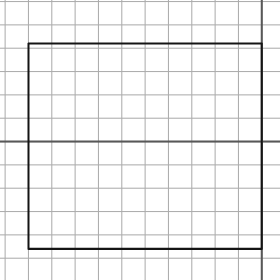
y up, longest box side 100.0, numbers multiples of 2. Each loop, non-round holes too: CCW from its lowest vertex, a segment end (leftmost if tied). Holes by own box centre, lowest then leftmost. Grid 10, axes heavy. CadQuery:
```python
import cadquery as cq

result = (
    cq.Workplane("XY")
    .moveTo(-100.0, -46.0)
    .lineTo(0.0, -46.0)
    .lineTo(0.0, 42.0)
    .lineTo(-100.0, 42.0)
    .close()
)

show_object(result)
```